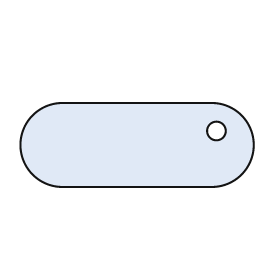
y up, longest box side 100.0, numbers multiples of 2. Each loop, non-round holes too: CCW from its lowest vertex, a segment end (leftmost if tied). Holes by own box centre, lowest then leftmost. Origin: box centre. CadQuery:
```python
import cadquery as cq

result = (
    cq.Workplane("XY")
    .moveTo(-32.0, -18.0)
    .lineTo(32.0, -18.0)
    .threePointArc((50.0, 0.0), (32.0, 18.0))
    .lineTo(-32.0, 18.0)
    .threePointArc((-50.0, 0.0), (-32.0, -18.0))
    .close()
    .moveTo(34.0, 6.0)
    .circle(4.0)
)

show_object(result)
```